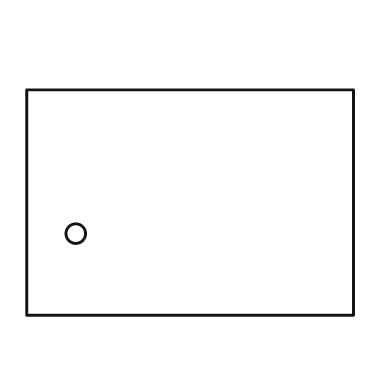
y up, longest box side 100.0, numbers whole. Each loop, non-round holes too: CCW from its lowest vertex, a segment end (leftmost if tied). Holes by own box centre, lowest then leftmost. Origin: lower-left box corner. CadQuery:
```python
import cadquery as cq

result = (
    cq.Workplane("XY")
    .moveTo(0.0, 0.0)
    .lineTo(100.0, 0.0)
    .lineTo(100.0, 69.0)
    .lineTo(0.0, 69.0)
    .close()
    .moveTo(15.0, 25.0)
    .circle(3.0)
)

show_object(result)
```